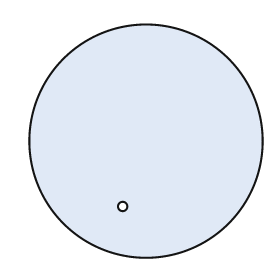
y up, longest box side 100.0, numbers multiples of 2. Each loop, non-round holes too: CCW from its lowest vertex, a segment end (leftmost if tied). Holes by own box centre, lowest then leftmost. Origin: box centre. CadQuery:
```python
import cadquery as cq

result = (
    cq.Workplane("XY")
    .moveTo(0.0, 0.0)
    .circle(50.0)
    .moveTo(-10.0, -28.0)
    .circle(2.0)
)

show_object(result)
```